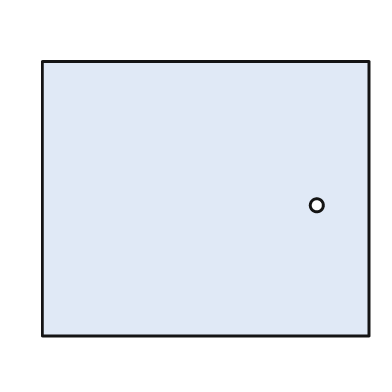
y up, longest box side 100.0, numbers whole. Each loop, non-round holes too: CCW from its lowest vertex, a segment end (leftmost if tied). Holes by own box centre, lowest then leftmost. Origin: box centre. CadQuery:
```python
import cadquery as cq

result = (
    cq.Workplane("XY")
    .moveTo(-50.0, -42.0)
    .lineTo(50.0, -42.0)
    .lineTo(50.0, 42.0)
    .lineTo(-50.0, 42.0)
    .close()
    .moveTo(34.0, -2.0)
    .circle(2.0)
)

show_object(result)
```